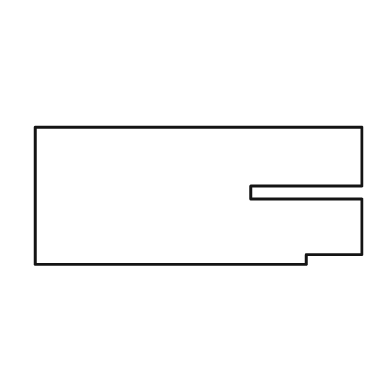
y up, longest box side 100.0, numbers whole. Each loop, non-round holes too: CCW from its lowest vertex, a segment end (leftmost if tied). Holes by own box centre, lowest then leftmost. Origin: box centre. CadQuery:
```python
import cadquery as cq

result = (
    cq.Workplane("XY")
    .moveTo(-50.0, -21.0)
    .lineTo(33.0, -21.0)
    .lineTo(33.0, -18.0)
    .lineTo(50.0, -18.0)
    .lineTo(50.0, -1.0)
    .lineTo(16.0, -1.0)
    .lineTo(16.0, 3.0)
    .lineTo(50.0, 3.0)
    .lineTo(50.0, 21.0)
    .lineTo(-50.0, 21.0)
    .close()
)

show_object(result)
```